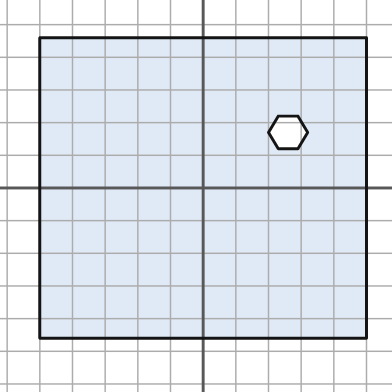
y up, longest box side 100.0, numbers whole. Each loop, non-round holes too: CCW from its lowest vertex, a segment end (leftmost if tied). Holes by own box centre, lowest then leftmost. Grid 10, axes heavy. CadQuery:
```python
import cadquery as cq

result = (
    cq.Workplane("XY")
    .moveTo(-50.0, -46.0)
    .lineTo(50.0, -46.0)
    .lineTo(50.0, 46.0)
    .lineTo(-50.0, 46.0)
    .close()
    .moveTo(23.0, 12.0)
    .lineTo(29.0, 12.0)
    .lineTo(32.0, 17.0)
    .lineTo(29.0, 22.0)
    .lineTo(23.0, 22.0)
    .lineTo(20.0, 17.0)
    .close()
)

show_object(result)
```